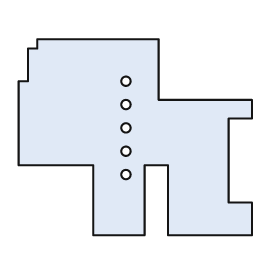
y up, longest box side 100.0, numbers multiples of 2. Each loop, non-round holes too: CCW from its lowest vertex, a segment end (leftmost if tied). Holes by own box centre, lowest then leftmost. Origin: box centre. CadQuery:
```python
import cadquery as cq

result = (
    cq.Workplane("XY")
    .moveTo(-18.0, -42.0)
    .lineTo(4.0, -42.0)
    .lineTo(4.0, -12.0)
    .lineTo(14.0, -12.0)
    .lineTo(14.0, -42.0)
    .lineTo(50.0, -42.0)
    .lineTo(50.0, -28.0)
    .lineTo(40.0, -28.0)
    .lineTo(40.0, 8.0)
    .lineTo(50.0, 8.0)
    .lineTo(50.0, 16.0)
    .lineTo(10.0, 16.0)
    .lineTo(10.0, 42.0)
    .lineTo(-42.0, 42.0)
    .lineTo(-42.0, 38.0)
    .lineTo(-46.0, 38.0)
    .lineTo(-46.0, 24.0)
    .lineTo(-50.0, 24.0)
    .lineTo(-50.0, -12.0)
    .lineTo(-18.0, -12.0)
    .close()
    .moveTo(-4.0, -16.0)
    .circle(2.0)
    .moveTo(-4.0, -6.0)
    .circle(2.0)
    .moveTo(-4.0, 4.0)
    .circle(2.0)
    .moveTo(-4.0, 14.0)
    .circle(2.0)
    .moveTo(-4.0, 24.0)
    .circle(2.0)
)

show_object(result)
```